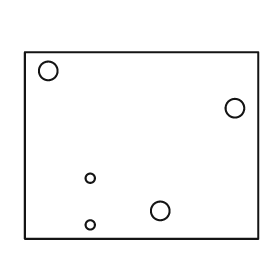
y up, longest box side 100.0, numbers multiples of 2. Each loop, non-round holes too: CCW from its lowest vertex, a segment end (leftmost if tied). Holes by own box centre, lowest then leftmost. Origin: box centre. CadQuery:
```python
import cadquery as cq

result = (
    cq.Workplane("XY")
    .moveTo(-50.0, -40.0)
    .lineTo(50.0, -40.0)
    .lineTo(50.0, 40.0)
    .lineTo(-50.0, 40.0)
    .close()
    .moveTo(-22.0, -34.0)
    .circle(2.0)
    .moveTo(8.0, -28.0)
    .circle(4.0)
    .moveTo(-22.0, -14.0)
    .circle(2.0)
    .moveTo(40.0, 16.0)
    .circle(4.0)
    .moveTo(-40.0, 32.0)
    .circle(4.0)
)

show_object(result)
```